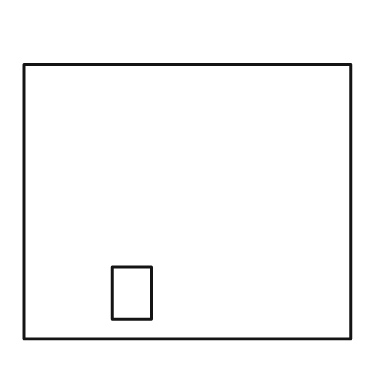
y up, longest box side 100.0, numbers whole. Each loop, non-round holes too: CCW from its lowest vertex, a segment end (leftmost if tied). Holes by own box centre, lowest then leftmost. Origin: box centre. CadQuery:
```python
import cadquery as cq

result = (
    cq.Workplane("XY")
    .moveTo(-50.0, -42.0)
    .lineTo(50.0, -42.0)
    .lineTo(50.0, 42.0)
    .lineTo(-50.0, 42.0)
    .close()
    .moveTo(-23.0, -36.0)
    .lineTo(-11.0, -36.0)
    .lineTo(-11.0, -20.0)
    .lineTo(-23.0, -20.0)
    .close()
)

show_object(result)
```